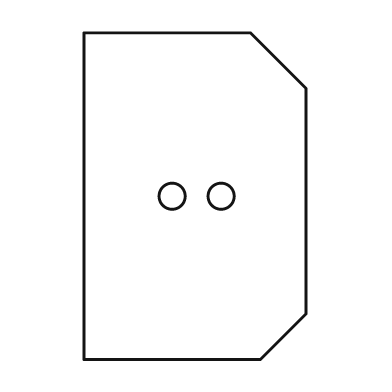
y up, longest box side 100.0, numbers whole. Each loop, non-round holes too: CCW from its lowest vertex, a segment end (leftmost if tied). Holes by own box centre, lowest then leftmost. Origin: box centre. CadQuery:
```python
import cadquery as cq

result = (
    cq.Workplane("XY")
    .moveTo(-34.0, -50.0)
    .lineTo(20.0, -50.0)
    .lineTo(34.0, -36.0)
    .lineTo(34.0, 33.0)
    .lineTo(17.0, 50.0)
    .lineTo(-34.0, 50.0)
    .close()
    .moveTo(-7.0, 0.0)
    .circle(4.0)
    .moveTo(8.0, 0.0)
    .circle(4.0)
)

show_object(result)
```